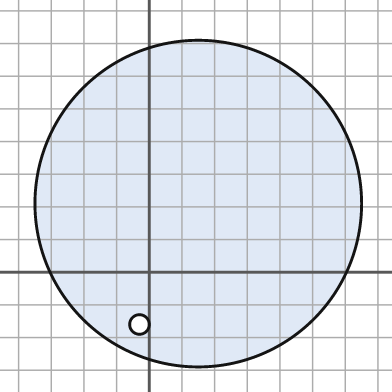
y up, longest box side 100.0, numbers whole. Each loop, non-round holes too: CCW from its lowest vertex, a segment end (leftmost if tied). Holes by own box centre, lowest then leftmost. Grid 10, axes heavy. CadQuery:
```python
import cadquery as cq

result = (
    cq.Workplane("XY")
    .moveTo(15.0, 21.0)
    .circle(50.0)
    .moveTo(-3.0, -16.0)
    .circle(3.0)
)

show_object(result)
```